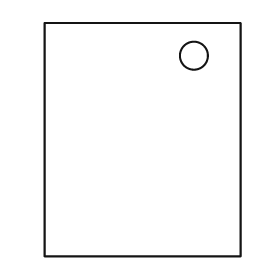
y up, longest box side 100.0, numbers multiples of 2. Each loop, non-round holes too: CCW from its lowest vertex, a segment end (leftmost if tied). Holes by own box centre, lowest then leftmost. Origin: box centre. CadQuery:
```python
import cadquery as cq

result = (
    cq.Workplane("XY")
    .moveTo(-42.0, -50.0)
    .lineTo(42.0, -50.0)
    .lineTo(42.0, 50.0)
    .lineTo(-42.0, 50.0)
    .close()
    .moveTo(22.0, 36.0)
    .circle(6.0)
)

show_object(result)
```